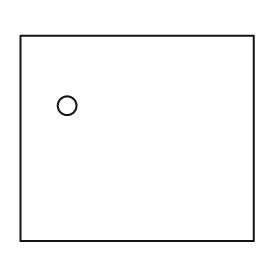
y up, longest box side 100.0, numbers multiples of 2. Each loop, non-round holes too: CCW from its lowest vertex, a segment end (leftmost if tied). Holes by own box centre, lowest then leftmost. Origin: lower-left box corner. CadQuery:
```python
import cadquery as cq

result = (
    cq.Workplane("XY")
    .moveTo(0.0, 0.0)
    .lineTo(100.0, 0.0)
    .lineTo(100.0, 88.0)
    .lineTo(0.0, 88.0)
    .close()
    .moveTo(20.0, 58.0)
    .circle(4.0)
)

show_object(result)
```